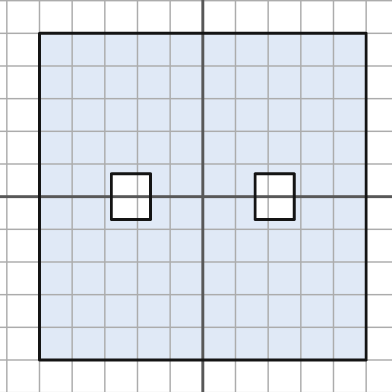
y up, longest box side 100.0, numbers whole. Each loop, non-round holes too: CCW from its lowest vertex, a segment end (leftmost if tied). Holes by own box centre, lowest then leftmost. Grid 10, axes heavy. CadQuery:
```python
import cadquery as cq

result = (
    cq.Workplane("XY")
    .moveTo(-50.0, -50.0)
    .lineTo(50.0, -50.0)
    .lineTo(50.0, 50.0)
    .lineTo(-50.0, 50.0)
    .close()
    .moveTo(-28.0, -7.0)
    .lineTo(-16.0, -7.0)
    .lineTo(-16.0, 7.0)
    .lineTo(-28.0, 7.0)
    .close()
    .moveTo(16.0, -7.0)
    .lineTo(28.0, -7.0)
    .lineTo(28.0, 7.0)
    .lineTo(16.0, 7.0)
    .close()
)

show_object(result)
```